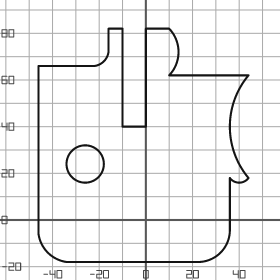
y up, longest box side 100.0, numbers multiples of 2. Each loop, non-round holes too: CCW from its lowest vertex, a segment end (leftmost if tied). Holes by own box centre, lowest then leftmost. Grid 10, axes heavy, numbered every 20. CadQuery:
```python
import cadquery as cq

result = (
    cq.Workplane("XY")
    .moveTo(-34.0, -18.0)
    .lineTo(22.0, -18.0)
    .threePointArc((32.0, -14.0), (36.0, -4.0))
    .lineTo(36.0, 18.0)
    .threePointArc((40.0, 16.0), (44.0, 18.0))
    .threePointArc((36.0, 40.0), (44.0, 62.0))
    .lineTo(10.0, 62.0)
    .threePointArc((14.0, 72.0), (10.0, 82.0))
    .lineTo(0.0, 82.0)
    .lineTo(0.0, 40.0)
    .lineTo(-10.0, 40.0)
    .lineTo(-10.0, 82.0)
    .lineTo(-16.0, 82.0)
    .lineTo(-16.0, 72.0)
    .threePointArc((-18.0, 68.0), (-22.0, 66.0))
    .lineTo(-46.0, 66.0)
    .lineTo(-46.0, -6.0)
    .threePointArc((-42.0, -14.0), (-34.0, -18.0))
    .close()
    .moveTo(-26.0, 24.0)
    .circle(8.0)
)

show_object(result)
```